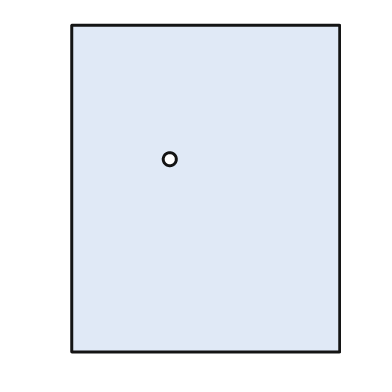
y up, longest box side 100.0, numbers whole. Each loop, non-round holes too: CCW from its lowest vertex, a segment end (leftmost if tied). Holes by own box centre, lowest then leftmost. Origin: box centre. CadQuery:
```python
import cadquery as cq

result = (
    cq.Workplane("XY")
    .moveTo(-41.0, -50.0)
    .lineTo(41.0, -50.0)
    .lineTo(41.0, 50.0)
    .lineTo(-41.0, 50.0)
    .close()
    .moveTo(-11.0, 9.0)
    .circle(2.0)
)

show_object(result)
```